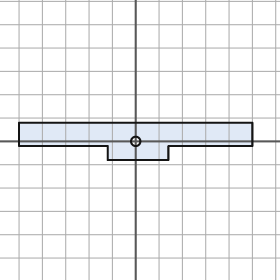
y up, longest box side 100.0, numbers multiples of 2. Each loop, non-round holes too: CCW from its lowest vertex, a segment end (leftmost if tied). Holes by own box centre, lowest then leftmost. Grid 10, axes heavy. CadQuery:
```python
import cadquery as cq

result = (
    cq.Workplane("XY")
    .moveTo(-12.0, -8.0)
    .lineTo(14.0, -8.0)
    .lineTo(14.0, -2.0)
    .lineTo(50.0, -2.0)
    .lineTo(50.0, 8.0)
    .lineTo(-50.0, 8.0)
    .lineTo(-50.0, -2.0)
    .lineTo(-12.0, -2.0)
    .close()
    .moveTo(0.0, 0.0)
    .circle(2.0)
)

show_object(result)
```